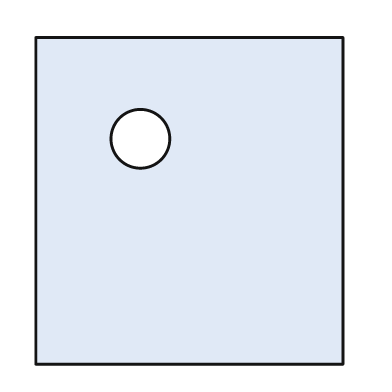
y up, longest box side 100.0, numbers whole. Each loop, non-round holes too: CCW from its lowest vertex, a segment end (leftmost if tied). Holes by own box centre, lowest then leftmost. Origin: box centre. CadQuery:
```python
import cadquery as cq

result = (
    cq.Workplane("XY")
    .moveTo(-47.0, -50.0)
    .lineTo(47.0, -50.0)
    .lineTo(47.0, 50.0)
    .lineTo(-47.0, 50.0)
    .close()
    .moveTo(-15.0, 19.0)
    .circle(9.0)
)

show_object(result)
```